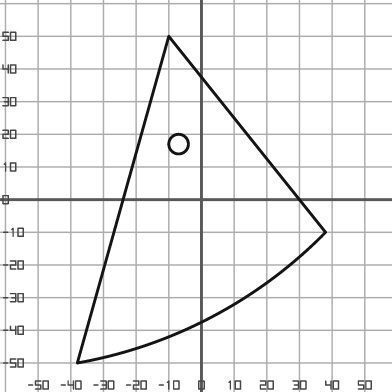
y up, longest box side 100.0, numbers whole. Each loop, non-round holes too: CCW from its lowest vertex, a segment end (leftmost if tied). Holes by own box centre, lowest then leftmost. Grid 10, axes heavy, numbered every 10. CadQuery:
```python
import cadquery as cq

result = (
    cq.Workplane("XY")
    .moveTo(-38.0, -50.0)
    .threePointArc((3.0, -36.0), (38.0, -10.0))
    .lineTo(-10.0, 50.0)
    .close()
    .moveTo(-7.0, 17.0)
    .circle(3.0)
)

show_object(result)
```